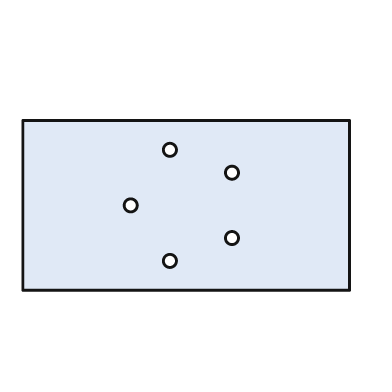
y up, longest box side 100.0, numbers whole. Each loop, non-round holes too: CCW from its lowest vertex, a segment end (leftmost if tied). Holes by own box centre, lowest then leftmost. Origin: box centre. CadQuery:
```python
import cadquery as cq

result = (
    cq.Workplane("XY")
    .moveTo(-50.0, -26.0)
    .lineTo(50.0, -26.0)
    .lineTo(50.0, 26.0)
    .lineTo(-50.0, 26.0)
    .close()
    .moveTo(-5.0, -17.0)
    .circle(2.0)
    .moveTo(14.0, -10.0)
    .circle(2.0)
    .moveTo(-17.0, 0.0)
    .circle(2.0)
    .moveTo(14.0, 10.0)
    .circle(2.0)
    .moveTo(-5.0, 17.0)
    .circle(2.0)
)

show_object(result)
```